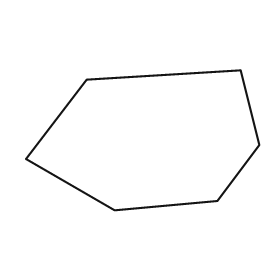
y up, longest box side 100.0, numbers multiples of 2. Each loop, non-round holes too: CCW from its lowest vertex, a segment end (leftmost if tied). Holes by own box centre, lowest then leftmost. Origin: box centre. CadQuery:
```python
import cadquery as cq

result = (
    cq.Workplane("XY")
    .moveTo(-12.0, -30.0)
    .lineTo(32.0, -26.0)
    .lineTo(50.0, -2.0)
    .lineTo(42.0, 30.0)
    .lineTo(-24.0, 26.0)
    .lineTo(-50.0, -8.0)
    .close()
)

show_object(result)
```